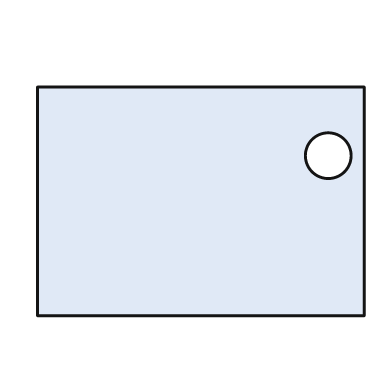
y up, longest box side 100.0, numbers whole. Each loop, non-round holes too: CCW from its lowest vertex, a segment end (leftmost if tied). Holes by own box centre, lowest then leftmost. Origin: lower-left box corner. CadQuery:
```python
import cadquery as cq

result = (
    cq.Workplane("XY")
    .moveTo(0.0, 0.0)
    .lineTo(100.0, 0.0)
    .lineTo(100.0, 70.0)
    .lineTo(0.0, 70.0)
    .close()
    .moveTo(89.0, 49.0)
    .circle(7.0)
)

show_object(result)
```